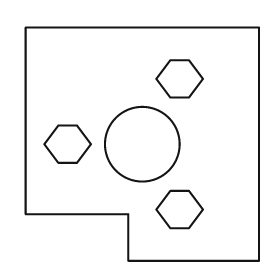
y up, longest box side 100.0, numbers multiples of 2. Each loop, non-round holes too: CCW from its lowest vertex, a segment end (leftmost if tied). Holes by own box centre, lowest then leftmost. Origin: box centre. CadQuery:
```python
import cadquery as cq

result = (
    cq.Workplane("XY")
    .moveTo(-6.0, -50.0)
    .lineTo(50.0, -50.0)
    .lineTo(50.0, 50.0)
    .lineTo(-50.0, 50.0)
    .lineTo(-50.0, -30.0)
    .lineTo(-6.0, -30.0)
    .close()
    .moveTo(12.0, -36.0)
    .lineTo(20.0, -36.0)
    .lineTo(26.0, -28.0)
    .lineTo(20.0, -20.0)
    .lineTo(12.0, -20.0)
    .lineTo(6.0, -28.0)
    .close()
    .moveTo(-36.0, -8.0)
    .lineTo(-28.0, -8.0)
    .lineTo(-22.0, 0.0)
    .lineTo(-28.0, 8.0)
    .lineTo(-36.0, 8.0)
    .lineTo(-42.0, 0.0)
    .close()
    .moveTo(0.0, 0.0)
    .circle(16.0)
    .moveTo(12.0, 20.0)
    .lineTo(20.0, 20.0)
    .lineTo(26.0, 28.0)
    .lineTo(20.0, 36.0)
    .lineTo(12.0, 36.0)
    .lineTo(6.0, 28.0)
    .close()
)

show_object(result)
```